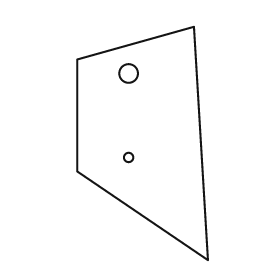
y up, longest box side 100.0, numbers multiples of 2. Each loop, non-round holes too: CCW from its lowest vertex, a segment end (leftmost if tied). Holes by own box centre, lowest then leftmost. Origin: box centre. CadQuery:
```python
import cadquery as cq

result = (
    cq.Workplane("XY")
    .moveTo(28.0, -50.0)
    .lineTo(22.0, 50.0)
    .lineTo(-28.0, 36.0)
    .lineTo(-28.0, -12.0)
    .close()
    .moveTo(-6.0, -6.0)
    .circle(2.0)
    .moveTo(-6.0, 30.0)
    .circle(4.0)
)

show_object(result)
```